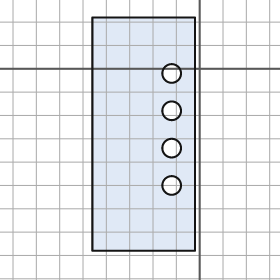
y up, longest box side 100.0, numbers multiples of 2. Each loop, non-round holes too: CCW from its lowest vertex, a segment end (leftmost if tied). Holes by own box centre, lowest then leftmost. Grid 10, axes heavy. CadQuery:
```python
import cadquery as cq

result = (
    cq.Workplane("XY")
    .moveTo(-46.0, -78.0)
    .lineTo(-2.0, -78.0)
    .lineTo(-2.0, 22.0)
    .lineTo(-46.0, 22.0)
    .close()
    .moveTo(-12.0, -50.0)
    .circle(4.0)
    .moveTo(-12.0, -34.0)
    .circle(4.0)
    .moveTo(-12.0, -18.0)
    .circle(4.0)
    .moveTo(-12.0, -2.0)
    .circle(4.0)
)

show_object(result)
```